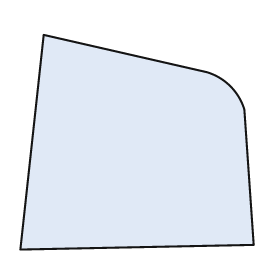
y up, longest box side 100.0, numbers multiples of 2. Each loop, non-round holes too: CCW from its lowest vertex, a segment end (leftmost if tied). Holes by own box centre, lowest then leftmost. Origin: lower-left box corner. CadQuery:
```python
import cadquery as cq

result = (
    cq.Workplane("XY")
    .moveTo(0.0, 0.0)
    .lineTo(100.0, 2.0)
    .lineTo(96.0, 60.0)
    .threePointArc((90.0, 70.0), (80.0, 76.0))
    .lineTo(10.0, 92.0)
    .close()
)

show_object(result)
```